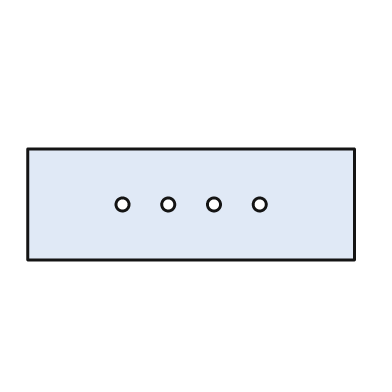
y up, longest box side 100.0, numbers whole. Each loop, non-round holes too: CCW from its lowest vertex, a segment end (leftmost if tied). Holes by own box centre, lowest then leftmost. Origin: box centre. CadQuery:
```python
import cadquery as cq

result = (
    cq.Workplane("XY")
    .moveTo(-50.0, -17.0)
    .lineTo(50.0, -17.0)
    .lineTo(50.0, 17.0)
    .lineTo(-50.0, 17.0)
    .close()
    .moveTo(-21.0, 0.0)
    .circle(2.0)
    .moveTo(-7.0, 0.0)
    .circle(2.0)
    .moveTo(7.0, 0.0)
    .circle(2.0)
    .moveTo(21.0, 0.0)
    .circle(2.0)
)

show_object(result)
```